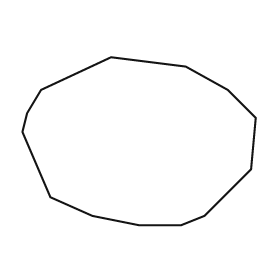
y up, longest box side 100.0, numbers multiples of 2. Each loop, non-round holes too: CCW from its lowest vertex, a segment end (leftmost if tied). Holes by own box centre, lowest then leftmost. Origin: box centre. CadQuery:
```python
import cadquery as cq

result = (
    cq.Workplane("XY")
    .moveTo(0.0, -36.0)
    .lineTo(18.0, -36.0)
    .lineTo(28.0, -32.0)
    .lineTo(48.0, -12.0)
    .lineTo(50.0, 10.0)
    .lineTo(38.0, 22.0)
    .lineTo(20.0, 32.0)
    .lineTo(-12.0, 36.0)
    .lineTo(-42.0, 22.0)
    .lineTo(-48.0, 12.0)
    .lineTo(-50.0, 4.0)
    .lineTo(-38.0, -24.0)
    .lineTo(-20.0, -32.0)
    .close()
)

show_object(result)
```